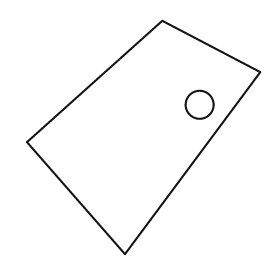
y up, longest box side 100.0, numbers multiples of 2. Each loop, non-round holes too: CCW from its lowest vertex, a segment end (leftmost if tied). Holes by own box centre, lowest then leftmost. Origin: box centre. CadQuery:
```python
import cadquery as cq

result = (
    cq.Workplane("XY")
    .moveTo(-8.0, -50.0)
    .lineTo(50.0, 28.0)
    .lineTo(8.0, 50.0)
    .lineTo(-50.0, -2.0)
    .close()
    .moveTo(24.0, 14.0)
    .circle(6.0)
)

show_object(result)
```